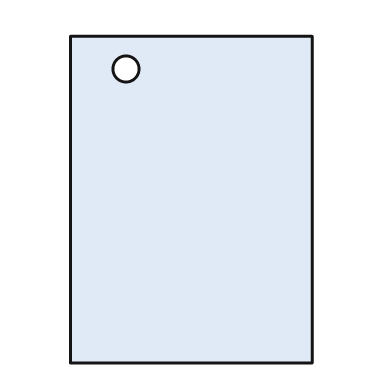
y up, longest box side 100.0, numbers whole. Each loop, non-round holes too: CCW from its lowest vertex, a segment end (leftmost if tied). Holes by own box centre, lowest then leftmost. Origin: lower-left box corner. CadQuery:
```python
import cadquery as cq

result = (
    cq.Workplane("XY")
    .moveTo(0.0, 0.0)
    .lineTo(74.0, 0.0)
    .lineTo(74.0, 100.0)
    .lineTo(0.0, 100.0)
    .close()
    .moveTo(17.0, 90.0)
    .circle(4.0)
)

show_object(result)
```